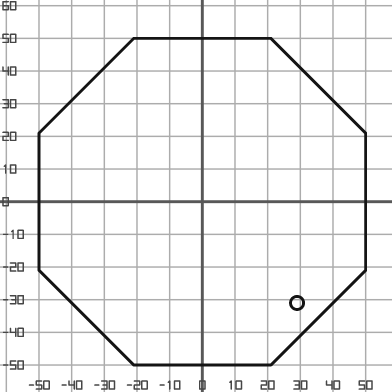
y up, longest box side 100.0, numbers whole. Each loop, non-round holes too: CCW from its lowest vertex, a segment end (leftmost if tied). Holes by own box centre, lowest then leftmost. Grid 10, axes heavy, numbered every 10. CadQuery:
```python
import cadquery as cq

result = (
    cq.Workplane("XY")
    .moveTo(-21.0, -50.0)
    .lineTo(21.0, -50.0)
    .lineTo(50.0, -21.0)
    .lineTo(50.0, 21.0)
    .lineTo(21.0, 50.0)
    .lineTo(-21.0, 50.0)
    .lineTo(-50.0, 21.0)
    .lineTo(-50.0, -21.0)
    .close()
    .moveTo(29.0, -31.0)
    .circle(2.0)
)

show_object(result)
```